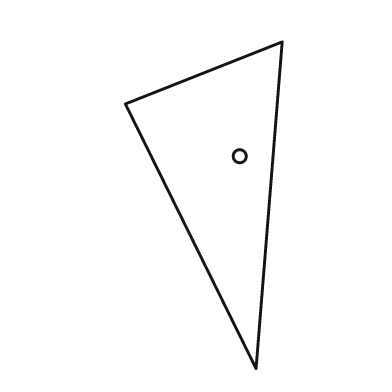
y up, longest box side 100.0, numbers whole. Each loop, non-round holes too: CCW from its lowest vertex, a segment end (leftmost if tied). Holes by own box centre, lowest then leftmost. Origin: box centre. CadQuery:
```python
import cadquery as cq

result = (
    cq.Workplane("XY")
    .moveTo(16.0, -50.0)
    .lineTo(24.0, 50.0)
    .lineTo(-24.0, 31.0)
    .close()
    .moveTo(11.0, 15.0)
    .circle(2.0)
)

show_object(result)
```